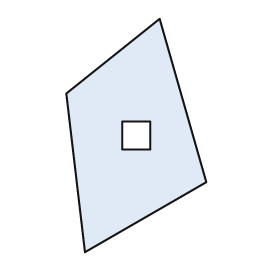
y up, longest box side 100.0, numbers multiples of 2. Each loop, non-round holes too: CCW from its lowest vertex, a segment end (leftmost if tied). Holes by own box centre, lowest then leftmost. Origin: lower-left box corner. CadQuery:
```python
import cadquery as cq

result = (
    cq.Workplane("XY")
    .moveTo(8.0, 0.0)
    .lineTo(60.0, 30.0)
    .lineTo(40.0, 100.0)
    .lineTo(0.0, 68.0)
    .close()
    .moveTo(24.0, 44.0)
    .lineTo(36.0, 44.0)
    .lineTo(36.0, 56.0)
    .lineTo(24.0, 56.0)
    .close()
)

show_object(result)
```